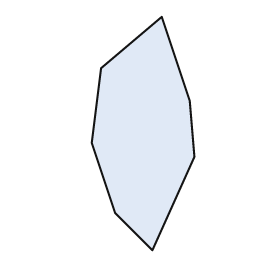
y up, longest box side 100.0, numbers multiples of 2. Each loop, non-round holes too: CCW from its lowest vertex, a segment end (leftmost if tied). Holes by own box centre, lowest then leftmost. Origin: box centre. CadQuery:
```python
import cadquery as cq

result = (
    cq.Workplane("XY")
    .moveTo(4.0, -50.0)
    .lineTo(22.0, -10.0)
    .lineTo(20.0, 14.0)
    .lineTo(8.0, 50.0)
    .lineTo(-18.0, 28.0)
    .lineTo(-22.0, -4.0)
    .lineTo(-12.0, -34.0)
    .close()
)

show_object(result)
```